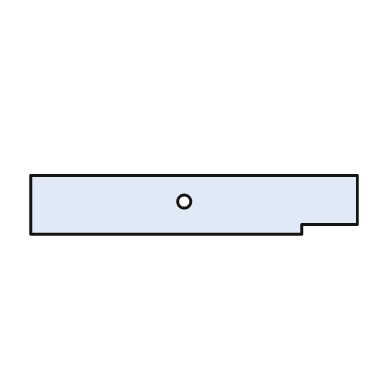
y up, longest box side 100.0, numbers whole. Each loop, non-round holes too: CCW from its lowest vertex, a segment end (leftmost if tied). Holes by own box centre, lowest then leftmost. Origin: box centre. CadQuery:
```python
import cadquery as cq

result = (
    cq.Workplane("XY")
    .moveTo(-50.0, -9.0)
    .lineTo(33.0, -9.0)
    .lineTo(33.0, -6.0)
    .lineTo(50.0, -6.0)
    .lineTo(50.0, 9.0)
    .lineTo(-50.0, 9.0)
    .close()
    .moveTo(-3.0, 1.0)
    .circle(2.0)
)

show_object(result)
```